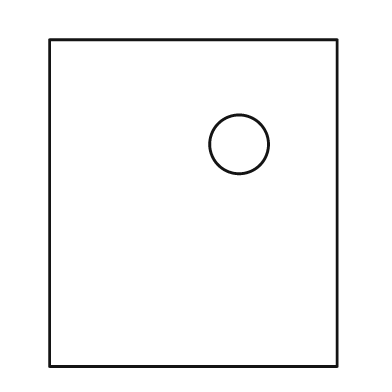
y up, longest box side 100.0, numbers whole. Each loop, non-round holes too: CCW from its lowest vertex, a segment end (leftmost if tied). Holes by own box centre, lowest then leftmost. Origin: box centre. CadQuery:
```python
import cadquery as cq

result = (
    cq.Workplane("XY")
    .moveTo(-44.0, -50.0)
    .lineTo(44.0, -50.0)
    .lineTo(44.0, 50.0)
    .lineTo(-44.0, 50.0)
    .close()
    .moveTo(14.0, 18.0)
    .circle(9.0)
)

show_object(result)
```